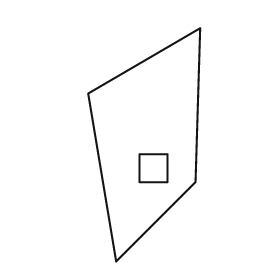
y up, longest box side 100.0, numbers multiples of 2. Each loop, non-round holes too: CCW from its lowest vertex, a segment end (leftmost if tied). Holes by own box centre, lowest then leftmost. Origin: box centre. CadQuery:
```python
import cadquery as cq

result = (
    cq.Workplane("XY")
    .moveTo(-12.0, -50.0)
    .lineTo(22.0, -16.0)
    .lineTo(24.0, 50.0)
    .lineTo(-24.0, 22.0)
    .close()
    .moveTo(-2.0, -16.0)
    .lineTo(10.0, -16.0)
    .lineTo(10.0, -4.0)
    .lineTo(-2.0, -4.0)
    .close()
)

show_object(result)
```